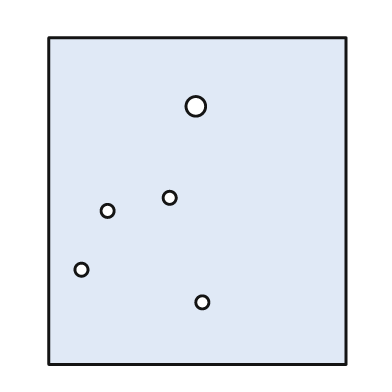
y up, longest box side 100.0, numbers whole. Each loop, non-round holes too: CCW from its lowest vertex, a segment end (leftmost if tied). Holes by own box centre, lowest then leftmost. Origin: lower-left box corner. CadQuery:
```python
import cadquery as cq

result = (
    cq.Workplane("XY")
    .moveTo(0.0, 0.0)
    .lineTo(91.0, 0.0)
    .lineTo(91.0, 100.0)
    .lineTo(0.0, 100.0)
    .close()
    .moveTo(47.0, 19.0)
    .circle(2.0)
    .moveTo(10.0, 29.0)
    .circle(2.0)
    .moveTo(18.0, 47.0)
    .circle(2.0)
    .moveTo(37.0, 51.0)
    .circle(2.0)
    .moveTo(45.0, 79.0)
    .circle(3.0)
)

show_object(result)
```